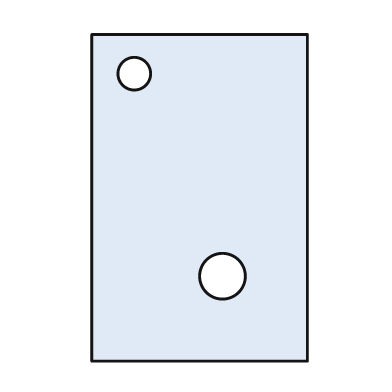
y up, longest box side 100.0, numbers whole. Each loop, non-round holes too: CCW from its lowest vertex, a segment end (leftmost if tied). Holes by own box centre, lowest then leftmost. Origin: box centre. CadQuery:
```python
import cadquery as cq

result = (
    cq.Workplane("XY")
    .moveTo(-33.0, -50.0)
    .lineTo(33.0, -50.0)
    .lineTo(33.0, 50.0)
    .lineTo(-33.0, 50.0)
    .close()
    .moveTo(7.0, -24.0)
    .circle(7.0)
    .moveTo(-20.0, 38.0)
    .circle(5.0)
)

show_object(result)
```